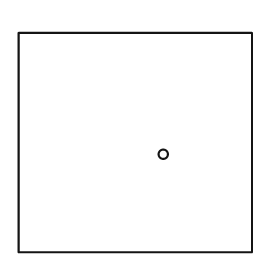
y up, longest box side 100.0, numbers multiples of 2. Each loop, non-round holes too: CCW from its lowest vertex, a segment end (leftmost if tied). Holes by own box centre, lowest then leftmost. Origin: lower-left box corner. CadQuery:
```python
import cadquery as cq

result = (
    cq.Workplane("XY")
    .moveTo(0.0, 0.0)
    .lineTo(100.0, 0.0)
    .lineTo(100.0, 94.0)
    .lineTo(0.0, 94.0)
    .close()
    .moveTo(62.0, 42.0)
    .circle(2.0)
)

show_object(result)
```